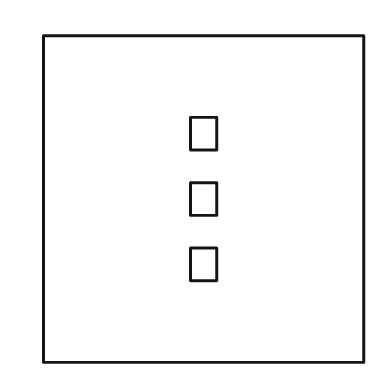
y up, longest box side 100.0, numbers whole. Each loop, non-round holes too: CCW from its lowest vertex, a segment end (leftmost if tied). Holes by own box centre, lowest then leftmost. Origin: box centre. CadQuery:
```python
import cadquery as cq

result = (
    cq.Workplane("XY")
    .moveTo(-49.0, -50.0)
    .lineTo(49.0, -50.0)
    .lineTo(49.0, 50.0)
    .lineTo(-49.0, 50.0)
    .close()
    .moveTo(-4.0, -25.0)
    .lineTo(4.0, -25.0)
    .lineTo(4.0, -15.0)
    .lineTo(-4.0, -15.0)
    .close()
    .moveTo(-4.0, -5.0)
    .lineTo(4.0, -5.0)
    .lineTo(4.0, 5.0)
    .lineTo(-4.0, 5.0)
    .close()
    .moveTo(-4.0, 15.0)
    .lineTo(4.0, 15.0)
    .lineTo(4.0, 25.0)
    .lineTo(-4.0, 25.0)
    .close()
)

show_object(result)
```